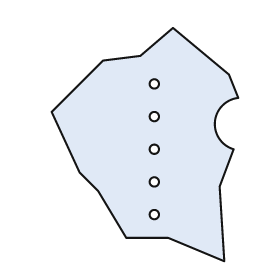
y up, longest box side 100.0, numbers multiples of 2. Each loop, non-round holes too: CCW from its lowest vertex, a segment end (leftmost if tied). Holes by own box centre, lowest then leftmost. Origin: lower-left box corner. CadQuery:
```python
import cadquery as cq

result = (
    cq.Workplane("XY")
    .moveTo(74.0, 0.0)
    .lineTo(72.0, 32.0)
    .lineTo(78.0, 48.0)
    .threePointArc((70.0, 60.0), (80.0, 70.0))
    .lineTo(76.0, 80.0)
    .lineTo(52.0, 100.0)
    .lineTo(38.0, 88.0)
    .lineTo(22.0, 86.0)
    .lineTo(0.0, 64.0)
    .lineTo(12.0, 38.0)
    .lineTo(20.0, 30.0)
    .lineTo(32.0, 10.0)
    .lineTo(50.0, 10.0)
    .close()
    .moveTo(44.0, 20.0)
    .circle(2.0)
    .moveTo(44.0, 34.0)
    .circle(2.0)
    .moveTo(44.0, 48.0)
    .circle(2.0)
    .moveTo(44.0, 62.0)
    .circle(2.0)
    .moveTo(44.0, 76.0)
    .circle(2.0)
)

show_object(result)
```